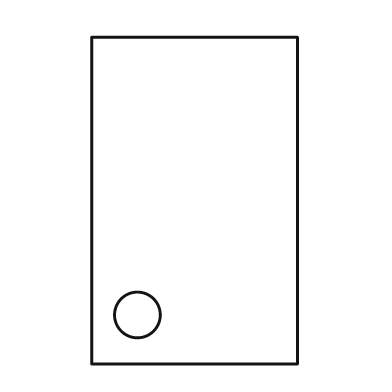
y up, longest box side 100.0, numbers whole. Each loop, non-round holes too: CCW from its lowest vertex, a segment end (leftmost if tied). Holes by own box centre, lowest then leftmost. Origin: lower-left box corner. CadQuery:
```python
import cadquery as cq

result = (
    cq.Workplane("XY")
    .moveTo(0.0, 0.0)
    .lineTo(63.0, 0.0)
    .lineTo(63.0, 100.0)
    .lineTo(0.0, 100.0)
    .close()
    .moveTo(14.0, 15.0)
    .circle(7.0)
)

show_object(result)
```